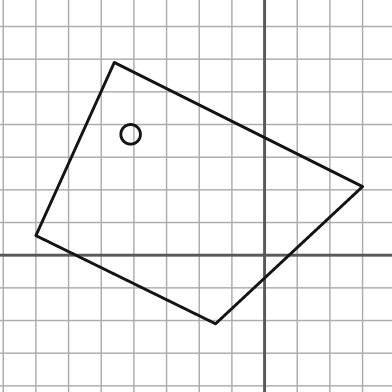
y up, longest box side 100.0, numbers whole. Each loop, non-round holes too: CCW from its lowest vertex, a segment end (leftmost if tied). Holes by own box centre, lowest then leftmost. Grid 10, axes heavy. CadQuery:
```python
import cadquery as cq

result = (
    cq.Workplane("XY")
    .moveTo(-15.0, -21.0)
    .lineTo(30.0, 21.0)
    .lineTo(-46.0, 59.0)
    .lineTo(-70.0, 6.0)
    .close()
    .moveTo(-41.0, 37.0)
    .circle(3.0)
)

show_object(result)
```